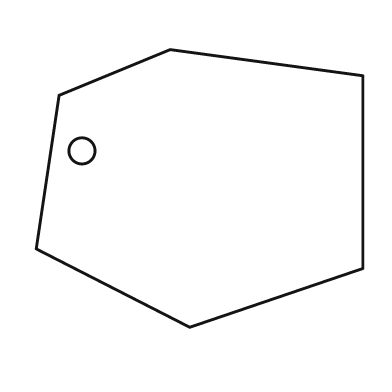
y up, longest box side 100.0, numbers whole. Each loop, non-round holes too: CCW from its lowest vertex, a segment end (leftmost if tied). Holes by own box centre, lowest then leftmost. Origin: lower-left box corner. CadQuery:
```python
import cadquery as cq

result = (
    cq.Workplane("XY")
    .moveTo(47.0, 0.0)
    .lineTo(100.0, 18.0)
    .lineTo(100.0, 77.0)
    .lineTo(41.0, 85.0)
    .lineTo(7.0, 71.0)
    .lineTo(0.0, 24.0)
    .close()
    .moveTo(14.0, 54.0)
    .circle(4.0)
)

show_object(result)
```